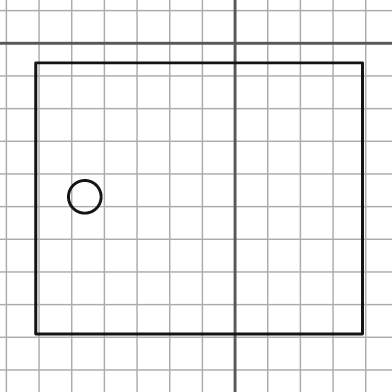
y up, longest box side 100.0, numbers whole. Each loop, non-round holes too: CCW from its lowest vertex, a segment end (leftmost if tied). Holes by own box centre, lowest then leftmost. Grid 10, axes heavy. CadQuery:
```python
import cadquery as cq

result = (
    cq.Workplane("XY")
    .moveTo(-61.0, -89.0)
    .lineTo(39.0, -89.0)
    .lineTo(39.0, -6.0)
    .lineTo(-61.0, -6.0)
    .close()
    .moveTo(-46.0, -47.0)
    .circle(5.0)
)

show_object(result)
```